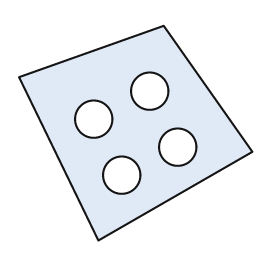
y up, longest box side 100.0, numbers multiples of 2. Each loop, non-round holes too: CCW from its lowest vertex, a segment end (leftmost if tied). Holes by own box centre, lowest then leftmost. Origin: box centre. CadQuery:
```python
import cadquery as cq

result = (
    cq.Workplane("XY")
    .moveTo(-16.0, -46.0)
    .lineTo(50.0, -8.0)
    .lineTo(12.0, 46.0)
    .lineTo(-50.0, 24.0)
    .close()
    .moveTo(-6.0, -18.0)
    .circle(8.0)
    .moveTo(18.0, -6.0)
    .circle(8.0)
    .moveTo(-18.0, 6.0)
    .circle(8.0)
    .moveTo(6.0, 18.0)
    .circle(8.0)
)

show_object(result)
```